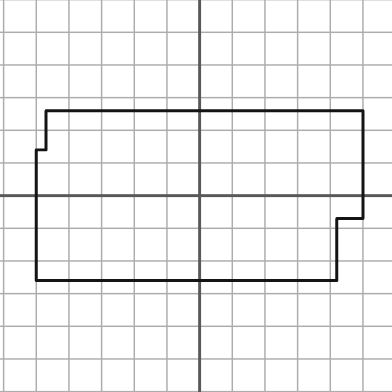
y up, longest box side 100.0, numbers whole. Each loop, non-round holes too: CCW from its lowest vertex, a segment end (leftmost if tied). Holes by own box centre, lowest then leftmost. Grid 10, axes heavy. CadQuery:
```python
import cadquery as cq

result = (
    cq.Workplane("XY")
    .moveTo(-50.0, -26.0)
    .lineTo(42.0, -26.0)
    .lineTo(42.0, -7.0)
    .lineTo(50.0, -7.0)
    .lineTo(50.0, 26.0)
    .lineTo(-47.0, 26.0)
    .lineTo(-47.0, 14.0)
    .lineTo(-50.0, 14.0)
    .close()
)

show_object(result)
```